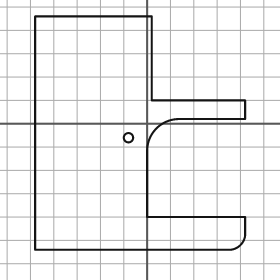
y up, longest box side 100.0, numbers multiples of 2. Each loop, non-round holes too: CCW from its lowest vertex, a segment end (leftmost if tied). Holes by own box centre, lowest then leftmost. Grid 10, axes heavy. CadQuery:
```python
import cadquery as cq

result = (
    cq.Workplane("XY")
    .moveTo(-48.0, -54.0)
    .lineTo(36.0, -54.0)
    .threePointArc((40.0, -52.0), (42.0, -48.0))
    .lineTo(42.0, -40.0)
    .lineTo(0.0, -40.0)
    .lineTo(0.0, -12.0)
    .threePointArc((4.0, -2.0), (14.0, 2.0))
    .lineTo(42.0, 2.0)
    .lineTo(42.0, 10.0)
    .lineTo(2.0, 10.0)
    .lineTo(2.0, 46.0)
    .lineTo(-48.0, 46.0)
    .close()
    .moveTo(-8.0, -6.0)
    .circle(2.0)
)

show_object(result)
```